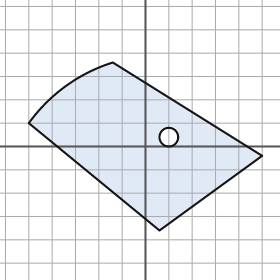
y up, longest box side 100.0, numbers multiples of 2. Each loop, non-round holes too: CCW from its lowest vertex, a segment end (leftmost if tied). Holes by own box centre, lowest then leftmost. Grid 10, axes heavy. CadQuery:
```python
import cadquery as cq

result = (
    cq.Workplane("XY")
    .moveTo(6.0, -36.0)
    .lineTo(50.0, -4.0)
    .lineTo(-14.0, 36.0)
    .threePointArc((-34.0, 26.0), (-50.0, 10.0))
    .close()
    .moveTo(10.0, 4.0)
    .circle(4.0)
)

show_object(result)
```